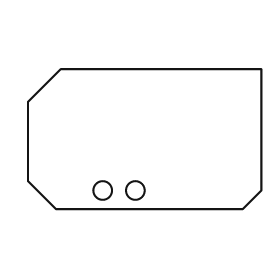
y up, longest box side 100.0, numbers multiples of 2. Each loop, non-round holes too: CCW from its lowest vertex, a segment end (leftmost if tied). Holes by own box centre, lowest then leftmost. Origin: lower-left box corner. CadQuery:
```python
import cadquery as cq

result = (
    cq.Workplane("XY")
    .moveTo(12.0, 0.0)
    .lineTo(92.0, 0.0)
    .lineTo(100.0, 8.0)
    .lineTo(100.0, 60.0)
    .lineTo(14.0, 60.0)
    .lineTo(0.0, 46.0)
    .lineTo(0.0, 12.0)
    .close()
    .moveTo(32.0, 8.0)
    .circle(4.0)
    .moveTo(46.0, 8.0)
    .circle(4.0)
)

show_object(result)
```